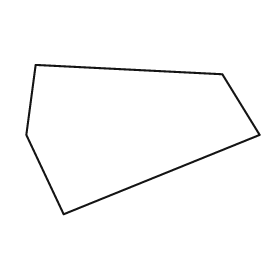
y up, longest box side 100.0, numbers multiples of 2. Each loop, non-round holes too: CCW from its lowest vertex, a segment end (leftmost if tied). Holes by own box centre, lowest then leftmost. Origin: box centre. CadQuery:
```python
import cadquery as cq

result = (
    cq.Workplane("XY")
    .moveTo(-34.0, -32.0)
    .lineTo(50.0, 2.0)
    .lineTo(34.0, 28.0)
    .lineTo(-46.0, 32.0)
    .lineTo(-50.0, 2.0)
    .close()
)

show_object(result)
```